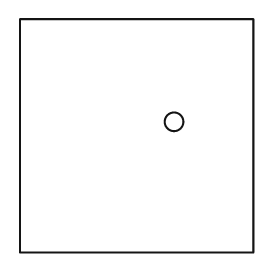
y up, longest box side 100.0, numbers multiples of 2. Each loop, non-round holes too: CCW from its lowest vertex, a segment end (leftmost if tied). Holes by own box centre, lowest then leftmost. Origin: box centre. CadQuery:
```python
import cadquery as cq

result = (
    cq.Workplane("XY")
    .moveTo(-50.0, -50.0)
    .lineTo(50.0, -50.0)
    .lineTo(50.0, 50.0)
    .lineTo(-50.0, 50.0)
    .close()
    .moveTo(16.0, 6.0)
    .circle(4.0)
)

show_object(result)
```